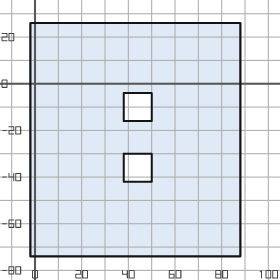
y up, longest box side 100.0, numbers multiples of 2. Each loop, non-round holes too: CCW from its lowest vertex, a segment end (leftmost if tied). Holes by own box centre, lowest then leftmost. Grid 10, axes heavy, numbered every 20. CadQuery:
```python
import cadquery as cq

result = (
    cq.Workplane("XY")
    .moveTo(-2.0, -74.0)
    .lineTo(88.0, -74.0)
    .lineTo(88.0, 26.0)
    .lineTo(-2.0, 26.0)
    .close()
    .moveTo(38.0, -42.0)
    .lineTo(50.0, -42.0)
    .lineTo(50.0, -30.0)
    .lineTo(38.0, -30.0)
    .close()
    .moveTo(38.0, -16.0)
    .lineTo(50.0, -16.0)
    .lineTo(50.0, -4.0)
    .lineTo(38.0, -4.0)
    .close()
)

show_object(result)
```